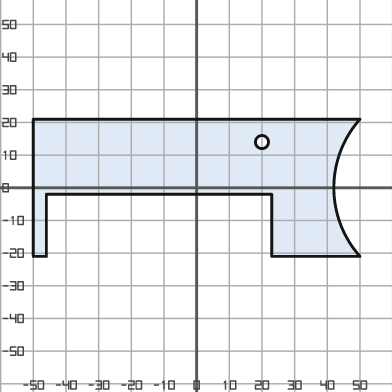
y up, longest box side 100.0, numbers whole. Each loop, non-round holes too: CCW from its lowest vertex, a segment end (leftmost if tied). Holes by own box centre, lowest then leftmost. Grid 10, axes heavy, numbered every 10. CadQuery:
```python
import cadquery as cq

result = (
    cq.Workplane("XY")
    .moveTo(-50.0, -21.0)
    .lineTo(-46.0, -21.0)
    .lineTo(-46.0, -2.0)
    .lineTo(23.0, -2.0)
    .lineTo(23.0, -21.0)
    .lineTo(50.0, -21.0)
    .threePointArc((42.0, 0.0), (50.0, 21.0))
    .lineTo(-50.0, 21.0)
    .close()
    .moveTo(20.0, 14.0)
    .circle(2.0)
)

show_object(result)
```